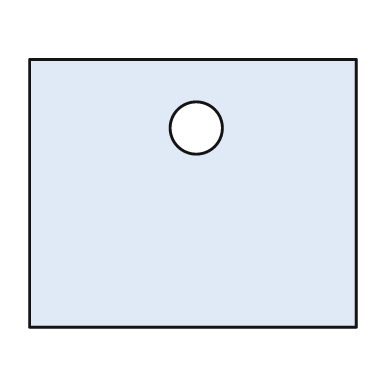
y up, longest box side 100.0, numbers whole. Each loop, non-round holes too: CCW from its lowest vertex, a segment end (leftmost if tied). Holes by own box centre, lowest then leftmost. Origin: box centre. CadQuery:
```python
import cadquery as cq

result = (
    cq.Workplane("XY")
    .moveTo(-50.0, -41.0)
    .lineTo(50.0, -41.0)
    .lineTo(50.0, 41.0)
    .lineTo(-50.0, 41.0)
    .close()
    .moveTo(1.0, 20.0)
    .circle(8.0)
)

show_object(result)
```